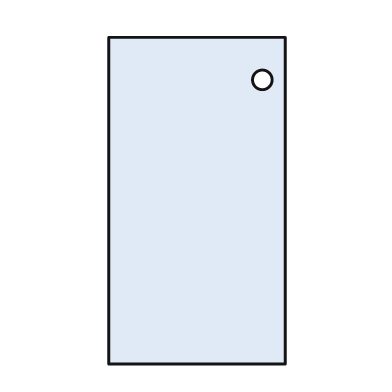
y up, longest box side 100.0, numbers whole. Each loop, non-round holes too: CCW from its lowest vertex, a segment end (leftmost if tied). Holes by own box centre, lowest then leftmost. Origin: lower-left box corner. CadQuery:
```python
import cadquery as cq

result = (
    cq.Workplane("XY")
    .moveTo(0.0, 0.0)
    .lineTo(54.0, 0.0)
    .lineTo(54.0, 100.0)
    .lineTo(0.0, 100.0)
    .close()
    .moveTo(47.0, 87.0)
    .circle(3.0)
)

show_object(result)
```